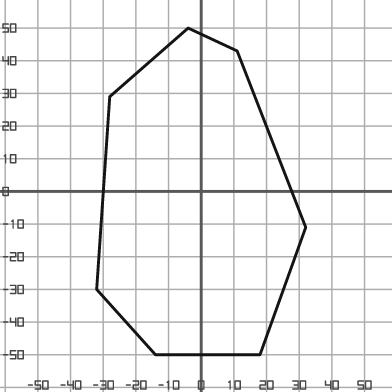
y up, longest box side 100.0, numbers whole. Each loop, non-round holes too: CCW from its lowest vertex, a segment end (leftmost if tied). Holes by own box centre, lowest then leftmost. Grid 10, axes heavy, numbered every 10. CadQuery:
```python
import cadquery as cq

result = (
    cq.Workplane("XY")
    .moveTo(-14.0, -50.0)
    .lineTo(18.0, -50.0)
    .lineTo(32.0, -11.0)
    .lineTo(11.0, 43.0)
    .lineTo(-4.0, 50.0)
    .lineTo(-28.0, 29.0)
    .lineTo(-32.0, -30.0)
    .close()
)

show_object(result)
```